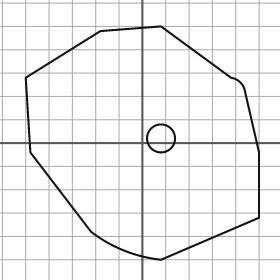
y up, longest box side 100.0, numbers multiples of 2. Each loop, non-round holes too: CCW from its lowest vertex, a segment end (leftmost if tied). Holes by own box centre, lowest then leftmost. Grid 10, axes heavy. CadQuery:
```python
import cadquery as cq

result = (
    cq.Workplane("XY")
    .moveTo(8.0, -50.0)
    .lineTo(50.0, -32.0)
    .lineTo(50.0, -4.0)
    .lineTo(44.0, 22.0)
    .threePointArc((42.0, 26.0), (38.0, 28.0))
    .lineTo(8.0, 50.0)
    .lineTo(-18.0, 48.0)
    .lineTo(-50.0, 28.0)
    .lineTo(-48.0, -4.0)
    .lineTo(-22.0, -38.0)
    .threePointArc((-8.0, -46.0), (8.0, -50.0))
    .close()
    .moveTo(8.0, 2.0)
    .circle(6.0)
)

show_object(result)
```